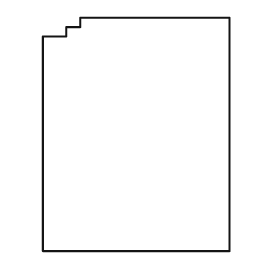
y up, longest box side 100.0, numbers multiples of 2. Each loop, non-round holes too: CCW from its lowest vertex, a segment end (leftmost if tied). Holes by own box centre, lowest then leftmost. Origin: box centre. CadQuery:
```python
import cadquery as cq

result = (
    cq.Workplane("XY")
    .moveTo(-40.0, -50.0)
    .lineTo(40.0, -50.0)
    .lineTo(40.0, 50.0)
    .lineTo(-24.0, 50.0)
    .lineTo(-24.0, 46.0)
    .lineTo(-30.0, 46.0)
    .lineTo(-30.0, 42.0)
    .lineTo(-40.0, 42.0)
    .close()
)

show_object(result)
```